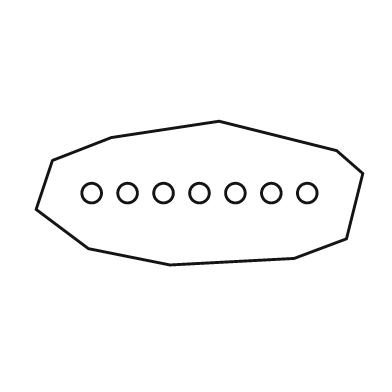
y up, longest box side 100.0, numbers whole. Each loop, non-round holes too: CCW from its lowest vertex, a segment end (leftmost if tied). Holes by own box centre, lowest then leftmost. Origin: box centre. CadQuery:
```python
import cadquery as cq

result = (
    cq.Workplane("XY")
    .moveTo(-9.0, -22.0)
    .lineTo(29.0, -20.0)
    .lineTo(45.0, -14.0)
    .lineTo(50.0, 6.0)
    .lineTo(42.0, 13.0)
    .lineTo(6.0, 22.0)
    .lineTo(-27.0, 17.0)
    .lineTo(-45.0, 10.0)
    .lineTo(-50.0, -5.0)
    .lineTo(-34.0, -17.0)
    .close()
    .moveTo(-33.0, 0.0)
    .circle(3.0)
    .moveTo(-22.0, 0.0)
    .circle(3.0)
    .moveTo(-11.0, 0.0)
    .circle(3.0)
    .moveTo(0.0, 0.0)
    .circle(3.0)
    .moveTo(11.0, 0.0)
    .circle(3.0)
    .moveTo(22.0, 0.0)
    .circle(3.0)
    .moveTo(33.0, 0.0)
    .circle(3.0)
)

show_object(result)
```